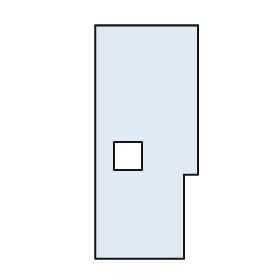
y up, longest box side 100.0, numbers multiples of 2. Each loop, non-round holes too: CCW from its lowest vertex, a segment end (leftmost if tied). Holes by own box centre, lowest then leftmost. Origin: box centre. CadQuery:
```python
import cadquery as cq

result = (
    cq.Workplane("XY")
    .moveTo(-22.0, -50.0)
    .lineTo(16.0, -50.0)
    .lineTo(16.0, -14.0)
    .lineTo(22.0, -14.0)
    .lineTo(22.0, 50.0)
    .lineTo(-22.0, 50.0)
    .close()
    .moveTo(-14.0, -12.0)
    .lineTo(-2.0, -12.0)
    .lineTo(-2.0, 0.0)
    .lineTo(-14.0, 0.0)
    .close()
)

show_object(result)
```